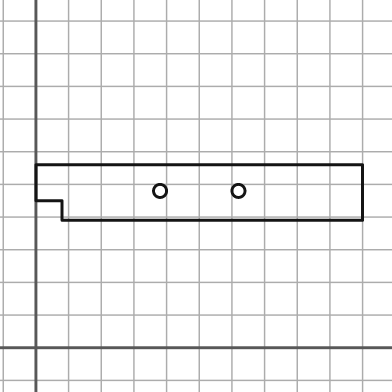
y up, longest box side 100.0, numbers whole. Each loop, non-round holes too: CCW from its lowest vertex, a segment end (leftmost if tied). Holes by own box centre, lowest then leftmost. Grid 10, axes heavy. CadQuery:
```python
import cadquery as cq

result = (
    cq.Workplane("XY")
    .moveTo(8.0, 39.0)
    .lineTo(100.0, 39.0)
    .lineTo(100.0, 56.0)
    .lineTo(0.0, 56.0)
    .lineTo(0.0, 45.0)
    .lineTo(8.0, 45.0)
    .close()
    .moveTo(38.0, 48.0)
    .circle(2.0)
    .moveTo(62.0, 48.0)
    .circle(2.0)
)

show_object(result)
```